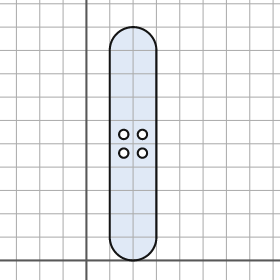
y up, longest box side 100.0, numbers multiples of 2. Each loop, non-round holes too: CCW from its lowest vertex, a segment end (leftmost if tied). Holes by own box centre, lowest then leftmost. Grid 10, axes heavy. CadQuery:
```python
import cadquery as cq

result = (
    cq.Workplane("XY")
    .moveTo(10.0, 10.0)
    .threePointArc((20.0, 0.0), (30.0, 10.0))
    .lineTo(30.0, 90.0)
    .threePointArc((20.0, 100.0), (10.0, 90.0))
    .close()
    .moveTo(16.0, 46.0)
    .circle(2.0)
    .moveTo(24.0, 46.0)
    .circle(2.0)
    .moveTo(16.0, 54.0)
    .circle(2.0)
    .moveTo(24.0, 54.0)
    .circle(2.0)
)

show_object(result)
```